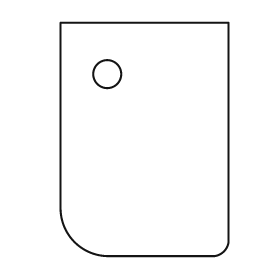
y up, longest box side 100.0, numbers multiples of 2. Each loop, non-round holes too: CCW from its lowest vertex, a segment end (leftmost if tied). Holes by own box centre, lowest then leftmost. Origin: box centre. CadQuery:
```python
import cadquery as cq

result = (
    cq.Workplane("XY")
    .moveTo(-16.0, -50.0)
    .lineTo(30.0, -50.0)
    .threePointArc((34.0, -48.0), (36.0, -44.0))
    .lineTo(36.0, 50.0)
    .lineTo(-36.0, 50.0)
    .lineTo(-36.0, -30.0)
    .threePointArc((-30.0, -44.0), (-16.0, -50.0))
    .close()
    .moveTo(-16.0, 28.0)
    .circle(6.0)
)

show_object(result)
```